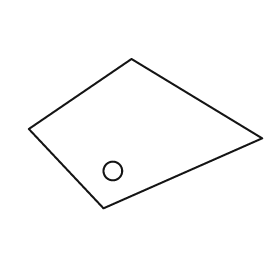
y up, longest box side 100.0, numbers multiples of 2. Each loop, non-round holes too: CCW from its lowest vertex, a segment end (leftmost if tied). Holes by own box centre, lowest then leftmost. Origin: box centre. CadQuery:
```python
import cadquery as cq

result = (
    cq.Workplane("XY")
    .moveTo(-18.0, -32.0)
    .lineTo(50.0, -2.0)
    .lineTo(-6.0, 32.0)
    .lineTo(-50.0, 2.0)
    .close()
    .moveTo(-14.0, -16.0)
    .circle(4.0)
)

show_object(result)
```